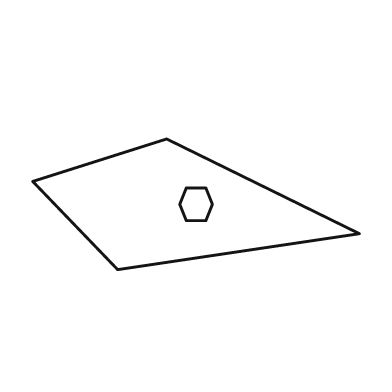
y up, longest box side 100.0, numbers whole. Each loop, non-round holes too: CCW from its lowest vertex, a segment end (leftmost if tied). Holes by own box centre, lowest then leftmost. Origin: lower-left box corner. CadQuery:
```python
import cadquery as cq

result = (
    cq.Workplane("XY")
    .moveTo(26.0, 0.0)
    .lineTo(100.0, 11.0)
    .lineTo(41.0, 40.0)
    .lineTo(0.0, 27.0)
    .close()
    .moveTo(47.0, 15.0)
    .lineTo(53.0, 15.0)
    .lineTo(55.0, 20.0)
    .lineTo(53.0, 25.0)
    .lineTo(47.0, 25.0)
    .lineTo(45.0, 20.0)
    .close()
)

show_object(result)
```